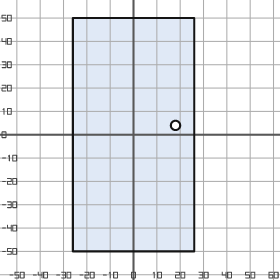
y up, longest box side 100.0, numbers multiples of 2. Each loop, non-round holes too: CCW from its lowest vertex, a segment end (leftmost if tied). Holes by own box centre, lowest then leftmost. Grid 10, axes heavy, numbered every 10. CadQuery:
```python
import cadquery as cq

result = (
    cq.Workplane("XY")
    .moveTo(-26.0, -50.0)
    .lineTo(26.0, -50.0)
    .lineTo(26.0, 50.0)
    .lineTo(-26.0, 50.0)
    .close()
    .moveTo(18.0, 4.0)
    .circle(2.0)
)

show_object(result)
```